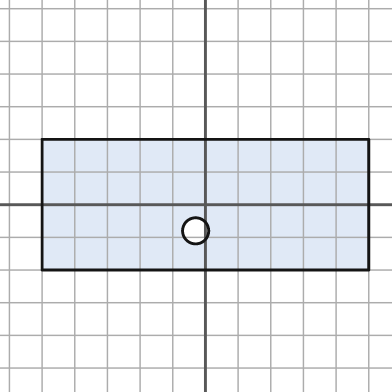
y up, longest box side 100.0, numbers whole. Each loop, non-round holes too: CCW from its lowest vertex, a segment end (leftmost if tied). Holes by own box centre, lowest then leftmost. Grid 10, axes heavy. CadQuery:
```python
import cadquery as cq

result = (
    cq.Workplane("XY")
    .moveTo(-50.0, -20.0)
    .lineTo(50.0, -20.0)
    .lineTo(50.0, 20.0)
    .lineTo(-50.0, 20.0)
    .close()
    .moveTo(-3.0, -8.0)
    .circle(4.0)
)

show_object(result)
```